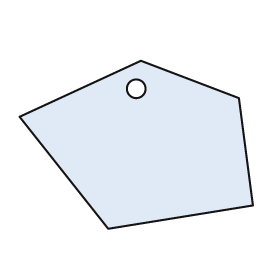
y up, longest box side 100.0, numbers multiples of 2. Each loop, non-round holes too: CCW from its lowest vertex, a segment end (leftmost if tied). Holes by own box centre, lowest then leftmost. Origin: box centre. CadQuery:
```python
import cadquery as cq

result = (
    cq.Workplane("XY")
    .moveTo(-12.0, -36.0)
    .lineTo(50.0, -26.0)
    .lineTo(44.0, 20.0)
    .lineTo(2.0, 36.0)
    .lineTo(-50.0, 12.0)
    .close()
    .moveTo(0.0, 24.0)
    .circle(4.0)
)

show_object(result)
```